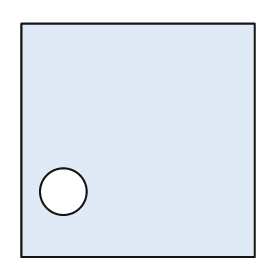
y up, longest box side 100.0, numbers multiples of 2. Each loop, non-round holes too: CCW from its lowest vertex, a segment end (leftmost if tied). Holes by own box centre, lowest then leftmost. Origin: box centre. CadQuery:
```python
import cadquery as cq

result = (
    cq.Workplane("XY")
    .moveTo(-50.0, -50.0)
    .lineTo(50.0, -50.0)
    .lineTo(50.0, 50.0)
    .lineTo(-50.0, 50.0)
    .close()
    .moveTo(-32.0, -22.0)
    .circle(10.0)
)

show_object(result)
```